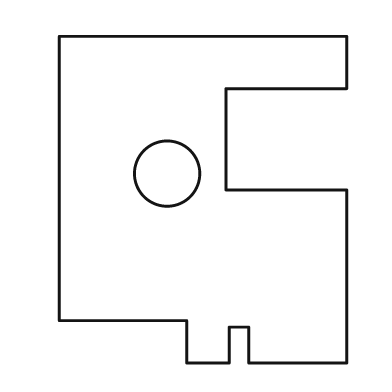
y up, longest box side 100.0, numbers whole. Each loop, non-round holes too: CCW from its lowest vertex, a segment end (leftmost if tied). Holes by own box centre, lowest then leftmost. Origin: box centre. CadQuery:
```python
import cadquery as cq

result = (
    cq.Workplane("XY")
    .moveTo(-5.0, -50.0)
    .lineTo(8.0, -50.0)
    .lineTo(8.0, -39.0)
    .lineTo(14.0, -39.0)
    .lineTo(14.0, -50.0)
    .lineTo(44.0, -50.0)
    .lineTo(44.0, 3.0)
    .lineTo(7.0, 3.0)
    .lineTo(7.0, 34.0)
    .lineTo(44.0, 34.0)
    .lineTo(44.0, 50.0)
    .lineTo(-44.0, 50.0)
    .lineTo(-44.0, -37.0)
    .lineTo(-5.0, -37.0)
    .close()
    .moveTo(-11.0, 8.0)
    .circle(10.0)
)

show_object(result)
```